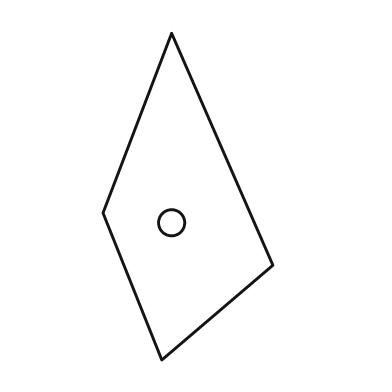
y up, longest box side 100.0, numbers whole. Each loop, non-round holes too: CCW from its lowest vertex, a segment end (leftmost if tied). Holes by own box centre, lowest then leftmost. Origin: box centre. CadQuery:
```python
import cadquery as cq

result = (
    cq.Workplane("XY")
    .moveTo(-8.0, -50.0)
    .lineTo(26.0, -21.0)
    .lineTo(-5.0, 50.0)
    .lineTo(-26.0, -5.0)
    .close()
    .moveTo(-5.0, -8.0)
    .circle(4.0)
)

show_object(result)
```